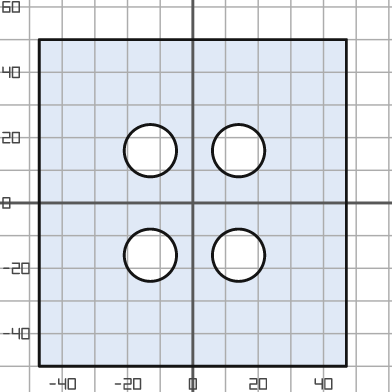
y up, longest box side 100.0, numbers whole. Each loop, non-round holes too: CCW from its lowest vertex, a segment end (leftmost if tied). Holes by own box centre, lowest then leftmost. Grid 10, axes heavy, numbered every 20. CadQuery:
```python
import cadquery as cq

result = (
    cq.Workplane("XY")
    .moveTo(-47.0, -50.0)
    .lineTo(47.0, -50.0)
    .lineTo(47.0, 50.0)
    .lineTo(-47.0, 50.0)
    .close()
    .moveTo(-13.0, -16.0)
    .circle(8.0)
    .moveTo(14.0, -16.0)
    .circle(8.0)
    .moveTo(-13.0, 16.0)
    .circle(8.0)
    .moveTo(14.0, 16.0)
    .circle(8.0)
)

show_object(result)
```